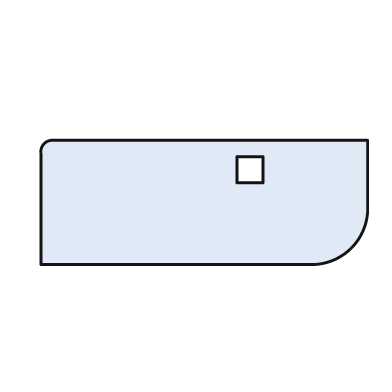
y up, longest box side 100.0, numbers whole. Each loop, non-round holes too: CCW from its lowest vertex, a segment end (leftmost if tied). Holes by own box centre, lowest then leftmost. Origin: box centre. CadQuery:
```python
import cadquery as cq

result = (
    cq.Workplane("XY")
    .moveTo(-50.0, -19.0)
    .lineTo(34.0, -19.0)
    .threePointArc((45.0, -14.0), (50.0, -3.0))
    .lineTo(50.0, 19.0)
    .lineTo(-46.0, 19.0)
    .threePointArc((-49.0, 18.0), (-50.0, 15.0))
    .close()
    .moveTo(10.0, 6.0)
    .lineTo(18.0, 6.0)
    .lineTo(18.0, 14.0)
    .lineTo(10.0, 14.0)
    .close()
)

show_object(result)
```